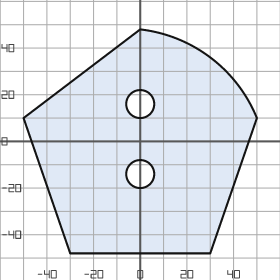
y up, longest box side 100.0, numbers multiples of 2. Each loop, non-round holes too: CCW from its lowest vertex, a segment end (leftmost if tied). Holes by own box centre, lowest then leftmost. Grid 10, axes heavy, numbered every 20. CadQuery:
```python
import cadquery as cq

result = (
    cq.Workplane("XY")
    .moveTo(-30.0, -48.0)
    .lineTo(30.0, -48.0)
    .lineTo(50.0, 10.0)
    .threePointArc((30.0, 36.0), (0.0, 48.0))
    .lineTo(-50.0, 10.0)
    .close()
    .moveTo(0.0, -14.0)
    .circle(6.0)
    .moveTo(0.0, 16.0)
    .circle(6.0)
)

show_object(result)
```